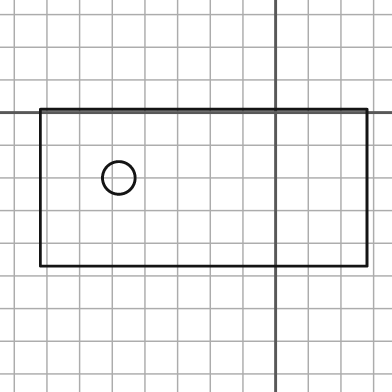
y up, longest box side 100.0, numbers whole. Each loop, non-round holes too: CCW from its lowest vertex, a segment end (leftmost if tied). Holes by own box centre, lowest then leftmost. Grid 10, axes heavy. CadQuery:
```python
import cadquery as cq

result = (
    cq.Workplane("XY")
    .moveTo(-72.0, -47.0)
    .lineTo(28.0, -47.0)
    .lineTo(28.0, 1.0)
    .lineTo(-72.0, 1.0)
    .close()
    .moveTo(-48.0, -20.0)
    .circle(5.0)
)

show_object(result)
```